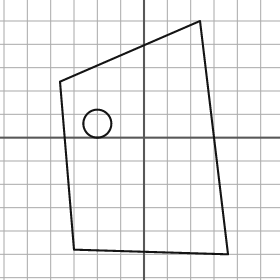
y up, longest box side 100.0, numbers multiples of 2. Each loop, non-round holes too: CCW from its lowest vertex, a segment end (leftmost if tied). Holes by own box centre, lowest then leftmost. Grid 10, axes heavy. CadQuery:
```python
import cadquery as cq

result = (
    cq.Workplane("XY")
    .moveTo(36.0, -50.0)
    .lineTo(24.0, 50.0)
    .lineTo(-36.0, 24.0)
    .lineTo(-30.0, -48.0)
    .close()
    .moveTo(-20.0, 6.0)
    .circle(6.0)
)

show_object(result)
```